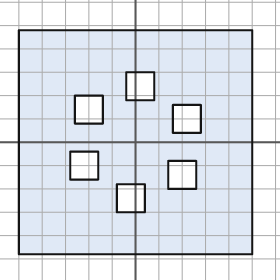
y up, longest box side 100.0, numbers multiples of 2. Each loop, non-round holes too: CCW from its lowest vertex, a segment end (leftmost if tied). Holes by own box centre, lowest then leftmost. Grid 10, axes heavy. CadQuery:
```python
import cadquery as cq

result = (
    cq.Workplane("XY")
    .moveTo(-50.0, -48.0)
    .lineTo(50.0, -48.0)
    .lineTo(50.0, 48.0)
    .lineTo(-50.0, 48.0)
    .close()
    .moveTo(-8.0, -30.0)
    .lineTo(4.0, -30.0)
    .lineTo(4.0, -18.0)
    .lineTo(-8.0, -18.0)
    .close()
    .moveTo(14.0, -20.0)
    .lineTo(26.0, -20.0)
    .lineTo(26.0, -8.0)
    .lineTo(14.0, -8.0)
    .close()
    .moveTo(-28.0, -16.0)
    .lineTo(-16.0, -16.0)
    .lineTo(-16.0, -4.0)
    .lineTo(-28.0, -4.0)
    .close()
    .moveTo(16.0, 4.0)
    .lineTo(28.0, 4.0)
    .lineTo(28.0, 16.0)
    .lineTo(16.0, 16.0)
    .close()
    .moveTo(-26.0, 8.0)
    .lineTo(-14.0, 8.0)
    .lineTo(-14.0, 20.0)
    .lineTo(-26.0, 20.0)
    .close()
    .moveTo(-4.0, 18.0)
    .lineTo(8.0, 18.0)
    .lineTo(8.0, 30.0)
    .lineTo(-4.0, 30.0)
    .close()
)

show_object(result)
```